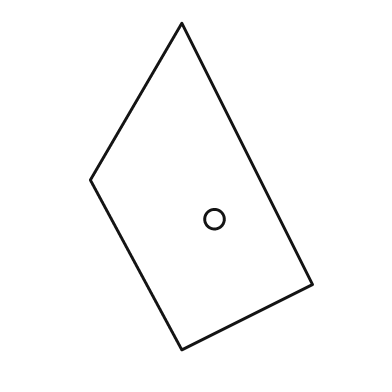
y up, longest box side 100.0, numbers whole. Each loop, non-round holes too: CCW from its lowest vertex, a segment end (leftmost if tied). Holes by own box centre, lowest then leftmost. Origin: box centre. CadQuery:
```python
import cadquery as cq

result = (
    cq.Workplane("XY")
    .moveTo(-6.0, -50.0)
    .lineTo(34.0, -30.0)
    .lineTo(-6.0, 50.0)
    .lineTo(-34.0, 2.0)
    .close()
    .moveTo(4.0, -10.0)
    .circle(3.0)
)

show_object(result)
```